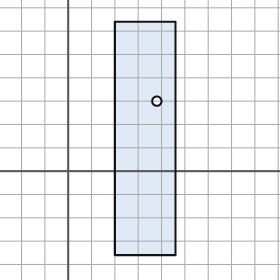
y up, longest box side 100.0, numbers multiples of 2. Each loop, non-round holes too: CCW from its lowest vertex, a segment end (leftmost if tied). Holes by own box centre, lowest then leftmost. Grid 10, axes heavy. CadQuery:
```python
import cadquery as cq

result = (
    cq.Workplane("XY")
    .moveTo(20.0, -36.0)
    .lineTo(46.0, -36.0)
    .lineTo(46.0, 64.0)
    .lineTo(20.0, 64.0)
    .close()
    .moveTo(38.0, 30.0)
    .circle(2.0)
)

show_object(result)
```